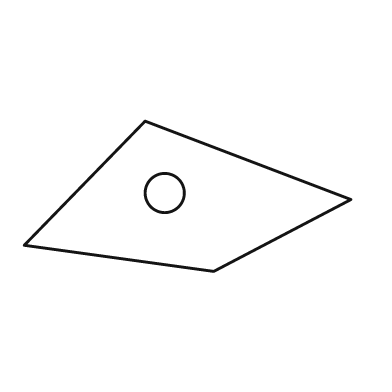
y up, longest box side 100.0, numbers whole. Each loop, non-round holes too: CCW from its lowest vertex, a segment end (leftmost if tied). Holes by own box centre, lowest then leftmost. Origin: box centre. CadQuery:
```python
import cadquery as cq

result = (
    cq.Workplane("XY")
    .moveTo(8.0, -23.0)
    .lineTo(50.0, -1.0)
    .lineTo(-13.0, 23.0)
    .lineTo(-50.0, -15.0)
    .close()
    .moveTo(-7.0, 1.0)
    .circle(6.0)
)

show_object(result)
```